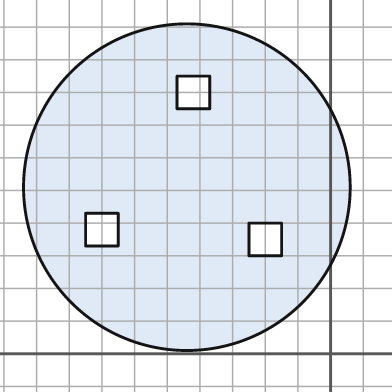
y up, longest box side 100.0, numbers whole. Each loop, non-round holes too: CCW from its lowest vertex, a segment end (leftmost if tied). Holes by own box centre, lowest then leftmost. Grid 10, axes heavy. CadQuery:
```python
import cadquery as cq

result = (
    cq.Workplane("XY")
    .moveTo(-44.0, 51.0)
    .circle(50.0)
    .moveTo(-25.0, 30.0)
    .lineTo(-15.0, 30.0)
    .lineTo(-15.0, 40.0)
    .lineTo(-25.0, 40.0)
    .close()
    .moveTo(-75.0, 33.0)
    .lineTo(-65.0, 33.0)
    .lineTo(-65.0, 43.0)
    .lineTo(-75.0, 43.0)
    .close()
    .moveTo(-47.0, 75.0)
    .lineTo(-37.0, 75.0)
    .lineTo(-37.0, 85.0)
    .lineTo(-47.0, 85.0)
    .close()
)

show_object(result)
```